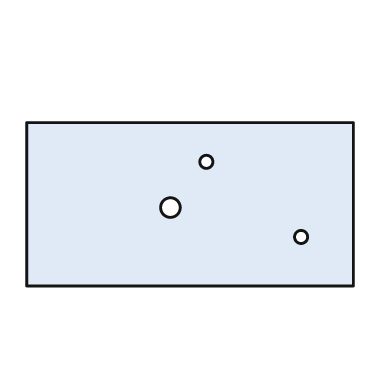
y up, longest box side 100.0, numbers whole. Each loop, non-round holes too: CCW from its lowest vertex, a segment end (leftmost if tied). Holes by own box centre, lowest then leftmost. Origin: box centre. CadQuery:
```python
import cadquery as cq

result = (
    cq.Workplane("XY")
    .moveTo(-50.0, -25.0)
    .lineTo(50.0, -25.0)
    .lineTo(50.0, 25.0)
    .lineTo(-50.0, 25.0)
    .close()
    .moveTo(34.0, -10.0)
    .circle(2.0)
    .moveTo(-6.0, -1.0)
    .circle(3.0)
    .moveTo(5.0, 13.0)
    .circle(2.0)
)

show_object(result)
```